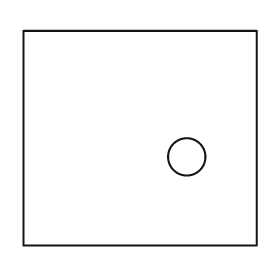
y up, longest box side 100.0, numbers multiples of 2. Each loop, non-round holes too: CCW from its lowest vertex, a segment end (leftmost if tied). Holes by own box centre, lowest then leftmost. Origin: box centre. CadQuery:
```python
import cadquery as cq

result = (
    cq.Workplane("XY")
    .moveTo(-50.0, -46.0)
    .lineTo(50.0, -46.0)
    .lineTo(50.0, 46.0)
    .lineTo(-50.0, 46.0)
    .close()
    .moveTo(20.0, -8.0)
    .circle(8.0)
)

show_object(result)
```